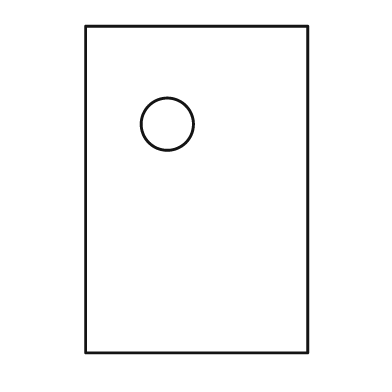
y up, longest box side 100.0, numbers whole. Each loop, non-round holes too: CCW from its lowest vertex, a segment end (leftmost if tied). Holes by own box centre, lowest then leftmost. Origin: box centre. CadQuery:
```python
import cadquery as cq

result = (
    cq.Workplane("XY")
    .moveTo(-34.0, -50.0)
    .lineTo(34.0, -50.0)
    .lineTo(34.0, 50.0)
    .lineTo(-34.0, 50.0)
    .close()
    .moveTo(-9.0, 20.0)
    .circle(8.0)
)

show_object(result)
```